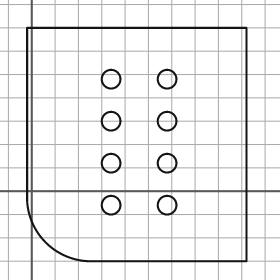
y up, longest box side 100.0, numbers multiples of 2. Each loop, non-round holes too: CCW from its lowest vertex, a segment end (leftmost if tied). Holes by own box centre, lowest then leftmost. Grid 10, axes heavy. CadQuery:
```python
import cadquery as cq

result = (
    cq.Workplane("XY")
    .moveTo(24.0, -30.0)
    .lineTo(92.0, -30.0)
    .lineTo(92.0, 70.0)
    .lineTo(-2.0, 70.0)
    .lineTo(-2.0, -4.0)
    .threePointArc((6.0, -22.0), (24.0, -30.0))
    .close()
    .moveTo(34.0, -6.0)
    .circle(4.0)
    .moveTo(58.0, -6.0)
    .circle(4.0)
    .moveTo(34.0, 12.0)
    .circle(4.0)
    .moveTo(58.0, 12.0)
    .circle(4.0)
    .moveTo(34.0, 30.0)
    .circle(4.0)
    .moveTo(58.0, 30.0)
    .circle(4.0)
    .moveTo(34.0, 48.0)
    .circle(4.0)
    .moveTo(58.0, 48.0)
    .circle(4.0)
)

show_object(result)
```